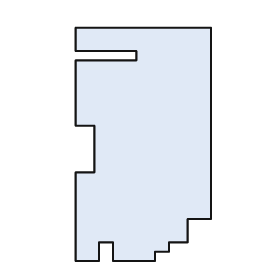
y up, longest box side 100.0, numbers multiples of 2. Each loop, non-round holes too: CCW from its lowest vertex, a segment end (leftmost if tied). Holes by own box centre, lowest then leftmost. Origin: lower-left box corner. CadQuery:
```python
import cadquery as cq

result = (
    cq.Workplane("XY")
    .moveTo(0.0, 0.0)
    .lineTo(10.0, 0.0)
    .lineTo(10.0, 8.0)
    .lineTo(16.0, 8.0)
    .lineTo(16.0, 0.0)
    .lineTo(34.0, 0.0)
    .lineTo(34.0, 4.0)
    .lineTo(40.0, 4.0)
    .lineTo(40.0, 8.0)
    .lineTo(48.0, 8.0)
    .lineTo(48.0, 18.0)
    .lineTo(58.0, 18.0)
    .lineTo(58.0, 100.0)
    .lineTo(0.0, 100.0)
    .lineTo(0.0, 90.0)
    .lineTo(26.0, 90.0)
    .lineTo(26.0, 86.0)
    .lineTo(0.0, 86.0)
    .lineTo(0.0, 58.0)
    .lineTo(8.0, 58.0)
    .lineTo(8.0, 38.0)
    .lineTo(0.0, 38.0)
    .close()
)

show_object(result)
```